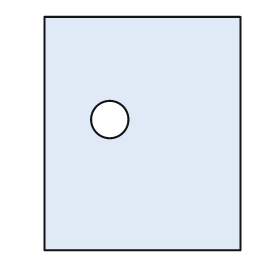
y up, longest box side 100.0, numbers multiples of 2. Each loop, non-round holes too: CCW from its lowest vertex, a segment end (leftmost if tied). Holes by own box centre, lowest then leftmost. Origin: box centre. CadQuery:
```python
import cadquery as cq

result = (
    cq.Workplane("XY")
    .moveTo(-42.0, -50.0)
    .lineTo(42.0, -50.0)
    .lineTo(42.0, 50.0)
    .lineTo(-42.0, 50.0)
    .close()
    .moveTo(-14.0, 6.0)
    .circle(8.0)
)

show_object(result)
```